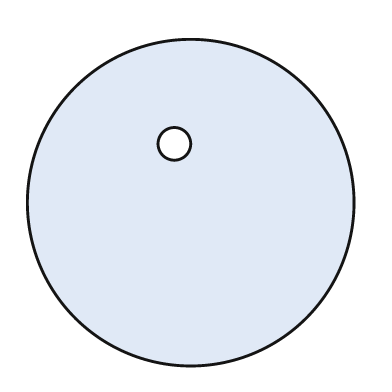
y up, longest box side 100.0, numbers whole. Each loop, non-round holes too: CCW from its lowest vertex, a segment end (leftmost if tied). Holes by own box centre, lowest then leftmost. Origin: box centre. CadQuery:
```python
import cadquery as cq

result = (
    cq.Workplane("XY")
    .moveTo(0.0, 0.0)
    .circle(50.0)
    .moveTo(-5.0, 18.0)
    .circle(5.0)
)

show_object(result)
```